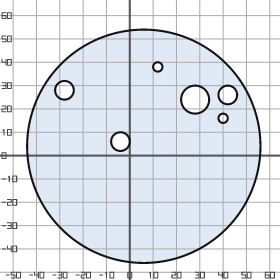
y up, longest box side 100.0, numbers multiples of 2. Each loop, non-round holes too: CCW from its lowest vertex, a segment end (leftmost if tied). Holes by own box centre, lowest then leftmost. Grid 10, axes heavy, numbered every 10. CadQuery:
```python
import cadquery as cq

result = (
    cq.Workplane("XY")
    .moveTo(6.0, 4.0)
    .circle(50.0)
    .moveTo(-4.0, 6.0)
    .circle(4.0)
    .moveTo(40.0, 16.0)
    .circle(2.0)
    .moveTo(28.0, 24.0)
    .circle(6.0)
    .moveTo(42.0, 26.0)
    .circle(4.0)
    .moveTo(-28.0, 28.0)
    .circle(4.0)
    .moveTo(12.0, 38.0)
    .circle(2.0)
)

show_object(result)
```